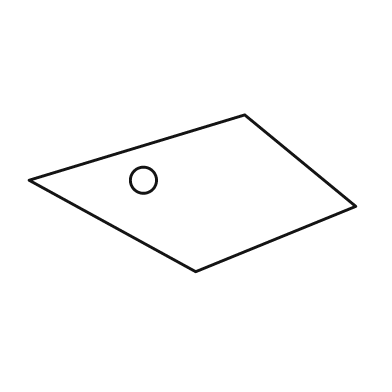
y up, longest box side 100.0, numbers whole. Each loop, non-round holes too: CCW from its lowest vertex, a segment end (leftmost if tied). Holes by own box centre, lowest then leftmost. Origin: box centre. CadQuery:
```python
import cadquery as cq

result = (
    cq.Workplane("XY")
    .moveTo(1.0, -24.0)
    .lineTo(50.0, -4.0)
    .lineTo(16.0, 24.0)
    .lineTo(-50.0, 4.0)
    .close()
    .moveTo(-15.0, 4.0)
    .circle(4.0)
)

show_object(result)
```